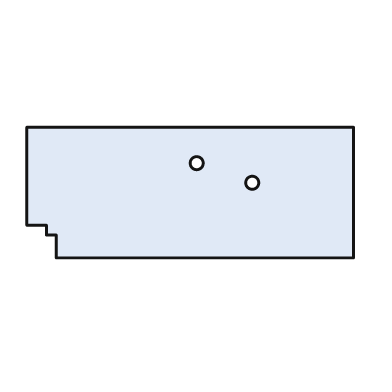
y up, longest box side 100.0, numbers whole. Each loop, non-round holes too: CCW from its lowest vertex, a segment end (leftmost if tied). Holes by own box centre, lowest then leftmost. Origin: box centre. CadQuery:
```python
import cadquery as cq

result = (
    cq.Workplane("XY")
    .moveTo(-41.0, -20.0)
    .lineTo(50.0, -20.0)
    .lineTo(50.0, 20.0)
    .lineTo(-50.0, 20.0)
    .lineTo(-50.0, -10.0)
    .lineTo(-44.0, -10.0)
    .lineTo(-44.0, -13.0)
    .lineTo(-41.0, -13.0)
    .close()
    .moveTo(19.0, 3.0)
    .circle(2.0)
    .moveTo(2.0, 9.0)
    .circle(2.0)
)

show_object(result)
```